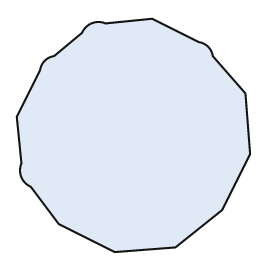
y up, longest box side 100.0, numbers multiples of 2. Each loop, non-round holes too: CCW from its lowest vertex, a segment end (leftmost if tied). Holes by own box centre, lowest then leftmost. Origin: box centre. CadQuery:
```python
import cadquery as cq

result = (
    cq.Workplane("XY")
    .moveTo(-8.0, -50.0)
    .lineTo(18.0, -48.0)
    .lineTo(38.0, -32.0)
    .lineTo(50.0, -8.0)
    .lineTo(48.0, 18.0)
    .lineTo(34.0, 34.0)
    .threePointArc((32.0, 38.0), (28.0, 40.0))
    .lineTo(8.0, 50.0)
    .lineTo(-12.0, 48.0)
    .threePointArc((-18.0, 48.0), (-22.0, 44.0))
    .lineTo(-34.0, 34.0)
    .threePointArc((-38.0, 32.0), (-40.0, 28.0))
    .lineTo(-50.0, 8.0)
    .lineTo(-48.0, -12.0)
    .threePointArc((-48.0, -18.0), (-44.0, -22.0))
    .lineTo(-32.0, -38.0)
    .close()
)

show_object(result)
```